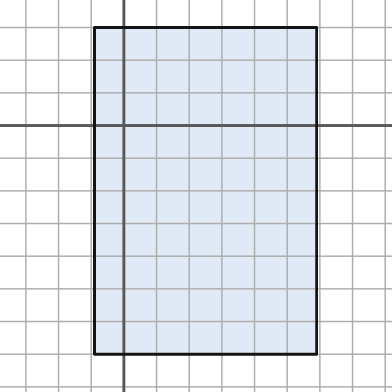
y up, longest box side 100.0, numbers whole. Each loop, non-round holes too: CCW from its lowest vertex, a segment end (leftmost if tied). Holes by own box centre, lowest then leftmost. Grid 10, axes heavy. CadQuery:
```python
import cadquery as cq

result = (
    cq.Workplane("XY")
    .moveTo(-9.0, -70.0)
    .lineTo(59.0, -70.0)
    .lineTo(59.0, 30.0)
    .lineTo(-9.0, 30.0)
    .close()
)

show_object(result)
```